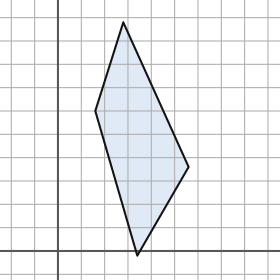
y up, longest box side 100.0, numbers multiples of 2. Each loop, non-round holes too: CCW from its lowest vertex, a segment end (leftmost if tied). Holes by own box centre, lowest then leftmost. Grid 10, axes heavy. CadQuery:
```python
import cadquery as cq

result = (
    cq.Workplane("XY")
    .moveTo(34.0, -2.0)
    .lineTo(56.0, 36.0)
    .lineTo(28.0, 98.0)
    .lineTo(16.0, 60.0)
    .close()
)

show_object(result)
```